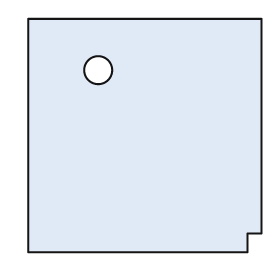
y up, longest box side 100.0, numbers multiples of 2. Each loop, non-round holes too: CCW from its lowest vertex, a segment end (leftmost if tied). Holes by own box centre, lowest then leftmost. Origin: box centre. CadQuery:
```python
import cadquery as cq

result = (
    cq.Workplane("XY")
    .moveTo(-50.0, -50.0)
    .lineTo(44.0, -50.0)
    .lineTo(44.0, -42.0)
    .lineTo(50.0, -42.0)
    .lineTo(50.0, 50.0)
    .lineTo(-50.0, 50.0)
    .close()
    .moveTo(-20.0, 28.0)
    .circle(6.0)
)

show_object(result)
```